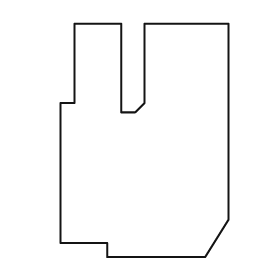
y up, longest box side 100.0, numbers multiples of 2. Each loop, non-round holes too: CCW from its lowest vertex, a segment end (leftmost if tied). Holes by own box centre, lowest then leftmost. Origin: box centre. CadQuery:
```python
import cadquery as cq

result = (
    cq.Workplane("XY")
    .moveTo(-16.0, -50.0)
    .lineTo(26.0, -50.0)
    .lineTo(36.0, -34.0)
    .lineTo(36.0, 50.0)
    .lineTo(0.0, 50.0)
    .lineTo(0.0, 16.0)
    .lineTo(-4.0, 12.0)
    .lineTo(-10.0, 12.0)
    .lineTo(-10.0, 50.0)
    .lineTo(-30.0, 50.0)
    .lineTo(-30.0, 16.0)
    .lineTo(-36.0, 16.0)
    .lineTo(-36.0, -44.0)
    .lineTo(-16.0, -44.0)
    .close()
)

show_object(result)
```